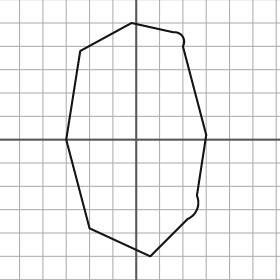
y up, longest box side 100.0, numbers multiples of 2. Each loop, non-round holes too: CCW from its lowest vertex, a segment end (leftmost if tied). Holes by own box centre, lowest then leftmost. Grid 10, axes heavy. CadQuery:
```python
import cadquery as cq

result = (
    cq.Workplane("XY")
    .moveTo(6.0, -50.0)
    .lineTo(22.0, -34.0)
    .threePointArc((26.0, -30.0), (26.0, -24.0))
    .lineTo(30.0, 2.0)
    .lineTo(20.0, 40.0)
    .threePointArc((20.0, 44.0), (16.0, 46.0))
    .lineTo(-2.0, 50.0)
    .lineTo(-24.0, 38.0)
    .lineTo(-30.0, 0.0)
    .lineTo(-20.0, -38.0)
    .close()
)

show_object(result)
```